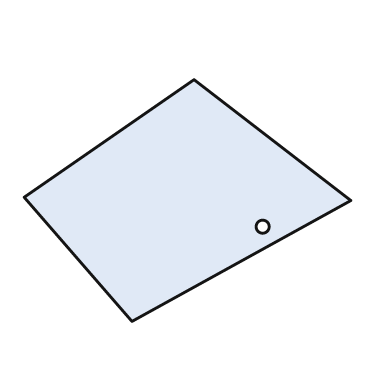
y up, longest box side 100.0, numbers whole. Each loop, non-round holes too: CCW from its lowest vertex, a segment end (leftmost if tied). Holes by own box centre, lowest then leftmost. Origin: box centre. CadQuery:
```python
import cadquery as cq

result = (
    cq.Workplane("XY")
    .moveTo(-17.0, -37.0)
    .lineTo(50.0, 0.0)
    .lineTo(2.0, 37.0)
    .lineTo(-50.0, 1.0)
    .close()
    .moveTo(23.0, -8.0)
    .circle(2.0)
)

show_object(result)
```